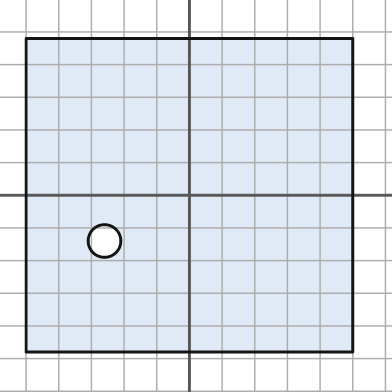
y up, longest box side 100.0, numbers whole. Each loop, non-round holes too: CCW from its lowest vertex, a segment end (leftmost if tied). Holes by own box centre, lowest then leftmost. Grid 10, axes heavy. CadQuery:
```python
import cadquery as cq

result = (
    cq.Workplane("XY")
    .moveTo(-50.0, -48.0)
    .lineTo(50.0, -48.0)
    .lineTo(50.0, 48.0)
    .lineTo(-50.0, 48.0)
    .close()
    .moveTo(-26.0, -14.0)
    .circle(5.0)
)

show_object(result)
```